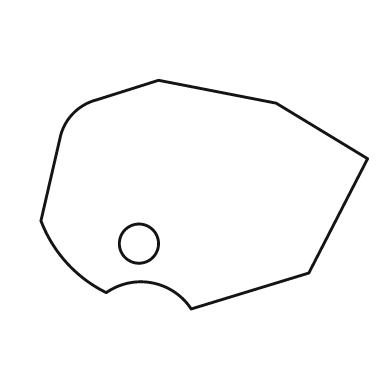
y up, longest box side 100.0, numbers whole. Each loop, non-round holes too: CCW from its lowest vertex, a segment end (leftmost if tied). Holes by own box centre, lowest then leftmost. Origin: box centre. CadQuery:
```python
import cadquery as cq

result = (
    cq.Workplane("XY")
    .moveTo(-4.0, -35.0)
    .lineTo(32.0, -24.0)
    .lineTo(50.0, 11.0)
    .lineTo(22.0, 28.0)
    .lineTo(-14.0, 35.0)
    .lineTo(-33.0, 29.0)
    .threePointArc((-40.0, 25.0), (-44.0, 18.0))
    .lineTo(-50.0, -8.0)
    .threePointArc((-42.0, -21.0), (-30.0, -30.0))
    .threePointArc((-16.0, -27.0), (-4.0, -35.0))
    .close()
    .moveTo(-20.0, -15.0)
    .circle(6.0)
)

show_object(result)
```